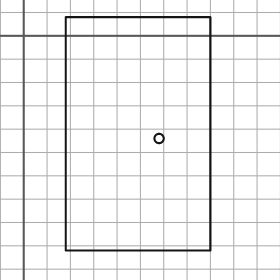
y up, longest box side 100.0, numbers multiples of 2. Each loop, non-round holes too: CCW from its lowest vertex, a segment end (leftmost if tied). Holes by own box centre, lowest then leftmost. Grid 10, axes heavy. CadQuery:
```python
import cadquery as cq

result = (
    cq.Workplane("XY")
    .moveTo(18.0, -92.0)
    .lineTo(80.0, -92.0)
    .lineTo(80.0, 8.0)
    .lineTo(18.0, 8.0)
    .close()
    .moveTo(58.0, -44.0)
    .circle(2.0)
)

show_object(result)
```